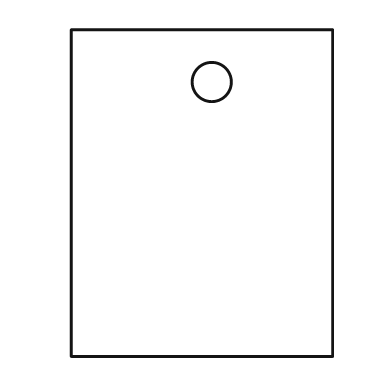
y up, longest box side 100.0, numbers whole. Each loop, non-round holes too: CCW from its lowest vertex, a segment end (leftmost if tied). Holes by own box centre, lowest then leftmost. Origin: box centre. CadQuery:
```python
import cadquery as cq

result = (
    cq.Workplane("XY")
    .moveTo(-40.0, -50.0)
    .lineTo(40.0, -50.0)
    .lineTo(40.0, 50.0)
    .lineTo(-40.0, 50.0)
    .close()
    .moveTo(3.0, 34.0)
    .circle(6.0)
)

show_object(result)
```